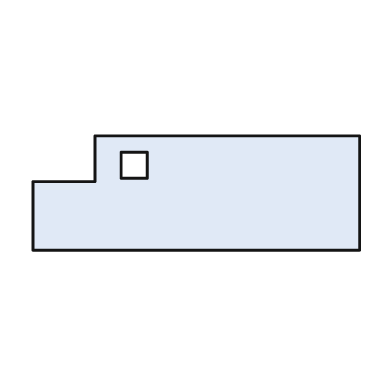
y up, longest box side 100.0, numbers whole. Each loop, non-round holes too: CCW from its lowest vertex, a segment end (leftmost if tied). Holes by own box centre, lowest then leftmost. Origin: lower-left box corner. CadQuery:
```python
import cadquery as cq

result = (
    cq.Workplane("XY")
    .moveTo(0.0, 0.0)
    .lineTo(100.0, 0.0)
    .lineTo(100.0, 35.0)
    .lineTo(19.0, 35.0)
    .lineTo(19.0, 21.0)
    .lineTo(0.0, 21.0)
    .close()
    .moveTo(27.0, 22.0)
    .lineTo(35.0, 22.0)
    .lineTo(35.0, 30.0)
    .lineTo(27.0, 30.0)
    .close()
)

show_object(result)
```